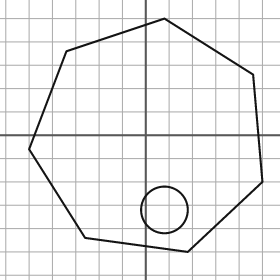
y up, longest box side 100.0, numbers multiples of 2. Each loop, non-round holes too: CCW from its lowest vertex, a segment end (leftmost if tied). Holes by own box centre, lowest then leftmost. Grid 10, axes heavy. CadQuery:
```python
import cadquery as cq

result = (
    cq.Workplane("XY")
    .moveTo(18.0, -50.0)
    .lineTo(50.0, -20.0)
    .lineTo(46.0, 26.0)
    .lineTo(8.0, 50.0)
    .lineTo(-34.0, 36.0)
    .lineTo(-50.0, -6.0)
    .lineTo(-26.0, -44.0)
    .close()
    .moveTo(8.0, -32.0)
    .circle(10.0)
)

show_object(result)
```